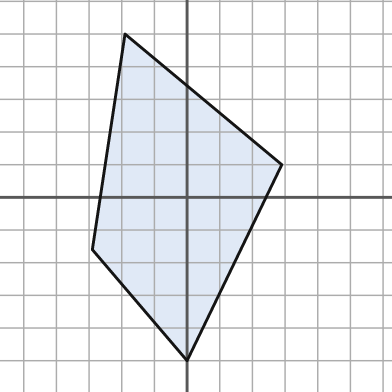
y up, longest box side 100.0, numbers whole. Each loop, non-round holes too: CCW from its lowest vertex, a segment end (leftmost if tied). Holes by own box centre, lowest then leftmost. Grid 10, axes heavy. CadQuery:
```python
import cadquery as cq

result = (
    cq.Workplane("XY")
    .moveTo(0.0, -50.0)
    .lineTo(29.0, 10.0)
    .lineTo(-19.0, 50.0)
    .lineTo(-29.0, -16.0)
    .close()
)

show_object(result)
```